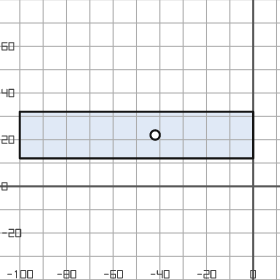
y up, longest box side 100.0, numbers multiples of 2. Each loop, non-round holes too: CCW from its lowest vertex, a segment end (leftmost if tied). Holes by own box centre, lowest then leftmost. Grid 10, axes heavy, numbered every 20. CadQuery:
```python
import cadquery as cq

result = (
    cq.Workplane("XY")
    .moveTo(-100.0, 12.0)
    .lineTo(0.0, 12.0)
    .lineTo(0.0, 32.0)
    .lineTo(-100.0, 32.0)
    .close()
    .moveTo(-42.0, 22.0)
    .circle(2.0)
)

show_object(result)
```